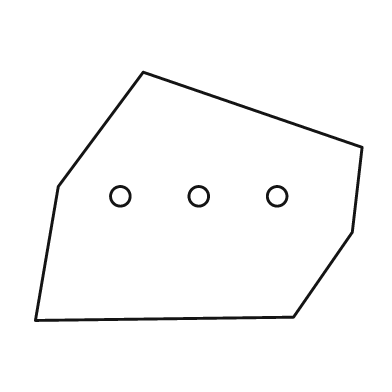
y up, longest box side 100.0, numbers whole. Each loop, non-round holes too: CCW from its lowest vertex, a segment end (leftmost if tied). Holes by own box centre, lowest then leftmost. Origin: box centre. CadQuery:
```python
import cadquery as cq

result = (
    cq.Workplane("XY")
    .moveTo(-50.0, -38.0)
    .lineTo(29.0, -37.0)
    .lineTo(47.0, -11.0)
    .lineTo(50.0, 15.0)
    .lineTo(-17.0, 38.0)
    .lineTo(-43.0, 3.0)
    .close()
    .moveTo(-24.0, 0.0)
    .circle(3.0)
    .moveTo(0.0, 0.0)
    .circle(3.0)
    .moveTo(24.0, 0.0)
    .circle(3.0)
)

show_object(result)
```